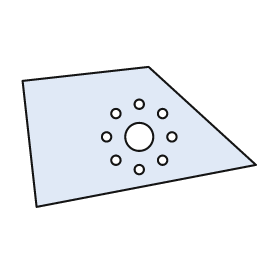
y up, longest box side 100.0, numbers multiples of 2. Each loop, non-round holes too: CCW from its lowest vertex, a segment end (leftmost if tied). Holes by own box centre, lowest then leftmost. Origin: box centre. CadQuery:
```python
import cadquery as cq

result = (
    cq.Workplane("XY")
    .moveTo(-44.0, -30.0)
    .lineTo(50.0, -12.0)
    .lineTo(4.0, 30.0)
    .lineTo(-50.0, 24.0)
    .close()
    .moveTo(0.0, -14.0)
    .circle(2.0)
    .moveTo(-10.0, -10.0)
    .circle(2.0)
    .moveTo(10.0, -10.0)
    .circle(2.0)
    .moveTo(-14.0, 0.0)
    .circle(2.0)
    .moveTo(0.0, 0.0)
    .circle(6.0)
    .moveTo(14.0, 0.0)
    .circle(2.0)
    .moveTo(-10.0, 10.0)
    .circle(2.0)
    .moveTo(10.0, 10.0)
    .circle(2.0)
    .moveTo(0.0, 14.0)
    .circle(2.0)
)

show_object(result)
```